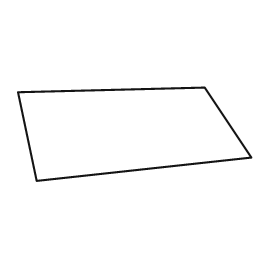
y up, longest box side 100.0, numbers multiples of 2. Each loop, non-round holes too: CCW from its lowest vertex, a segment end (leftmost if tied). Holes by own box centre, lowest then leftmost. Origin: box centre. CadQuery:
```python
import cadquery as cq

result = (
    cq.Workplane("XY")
    .moveTo(-42.0, -20.0)
    .lineTo(50.0, -10.0)
    .lineTo(30.0, 20.0)
    .lineTo(-50.0, 18.0)
    .close()
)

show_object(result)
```